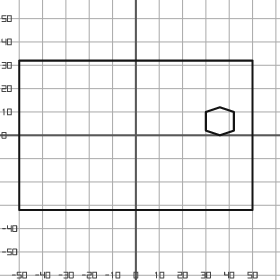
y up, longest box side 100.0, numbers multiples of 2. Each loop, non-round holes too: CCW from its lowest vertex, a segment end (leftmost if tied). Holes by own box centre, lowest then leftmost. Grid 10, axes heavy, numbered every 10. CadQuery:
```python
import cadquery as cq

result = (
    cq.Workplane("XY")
    .moveTo(-50.0, -32.0)
    .lineTo(50.0, -32.0)
    .lineTo(50.0, 32.0)
    .lineTo(-50.0, 32.0)
    .close()
    .moveTo(36.0, 0.0)
    .lineTo(42.0, 2.0)
    .lineTo(42.0, 10.0)
    .lineTo(36.0, 12.0)
    .lineTo(30.0, 10.0)
    .lineTo(30.0, 2.0)
    .close()
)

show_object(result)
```